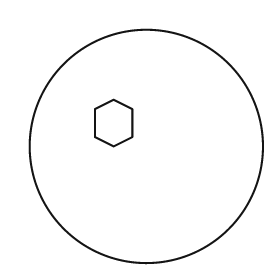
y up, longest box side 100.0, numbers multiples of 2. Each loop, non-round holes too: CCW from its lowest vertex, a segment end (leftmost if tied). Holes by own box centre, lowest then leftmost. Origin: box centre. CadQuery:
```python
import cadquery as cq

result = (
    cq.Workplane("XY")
    .moveTo(0.0, 0.0)
    .circle(50.0)
    .moveTo(-14.0, 0.0)
    .lineTo(-6.0, 4.0)
    .lineTo(-6.0, 16.0)
    .lineTo(-14.0, 20.0)
    .lineTo(-22.0, 16.0)
    .lineTo(-22.0, 4.0)
    .close()
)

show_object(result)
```